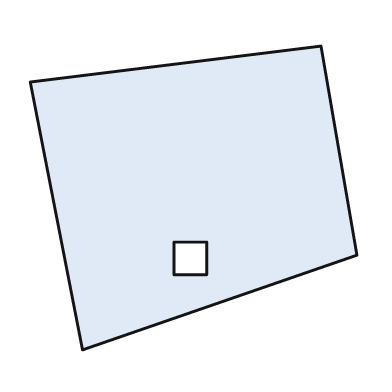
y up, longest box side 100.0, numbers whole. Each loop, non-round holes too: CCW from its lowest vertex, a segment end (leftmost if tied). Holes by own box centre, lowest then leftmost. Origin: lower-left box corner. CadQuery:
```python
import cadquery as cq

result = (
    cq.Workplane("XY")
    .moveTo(16.0, 0.0)
    .lineTo(100.0, 29.0)
    .lineTo(89.0, 93.0)
    .lineTo(0.0, 82.0)
    .close()
    .moveTo(44.0, 23.0)
    .lineTo(54.0, 23.0)
    .lineTo(54.0, 33.0)
    .lineTo(44.0, 33.0)
    .close()
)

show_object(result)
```